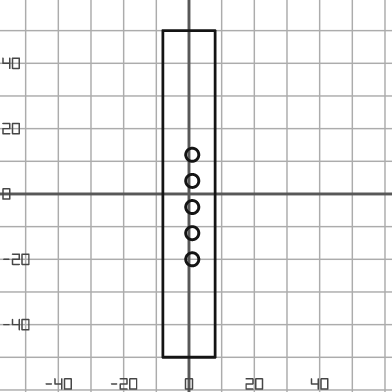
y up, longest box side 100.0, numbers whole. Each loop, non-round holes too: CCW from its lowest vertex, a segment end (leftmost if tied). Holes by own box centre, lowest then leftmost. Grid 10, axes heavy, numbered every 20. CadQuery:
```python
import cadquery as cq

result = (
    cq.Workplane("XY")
    .moveTo(-8.0, -50.0)
    .lineTo(8.0, -50.0)
    .lineTo(8.0, 50.0)
    .lineTo(-8.0, 50.0)
    .close()
    .moveTo(1.0, -20.0)
    .circle(2.0)
    .moveTo(1.0, -12.0)
    .circle(2.0)
    .moveTo(1.0, -4.0)
    .circle(2.0)
    .moveTo(1.0, 4.0)
    .circle(2.0)
    .moveTo(1.0, 12.0)
    .circle(2.0)
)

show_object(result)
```